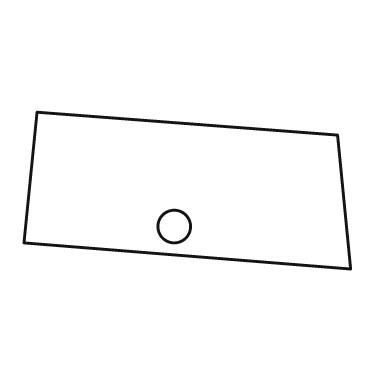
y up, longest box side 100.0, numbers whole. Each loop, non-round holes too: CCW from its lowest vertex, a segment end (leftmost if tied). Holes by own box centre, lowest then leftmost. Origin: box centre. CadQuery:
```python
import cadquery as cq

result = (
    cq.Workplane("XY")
    .moveTo(50.0, -24.0)
    .lineTo(46.0, 17.0)
    .lineTo(-46.0, 24.0)
    .lineTo(-50.0, -16.0)
    .close()
    .moveTo(-4.0, -11.0)
    .circle(5.0)
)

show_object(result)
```